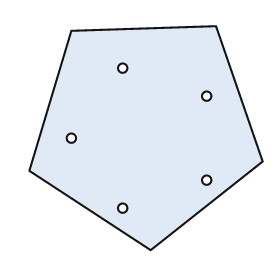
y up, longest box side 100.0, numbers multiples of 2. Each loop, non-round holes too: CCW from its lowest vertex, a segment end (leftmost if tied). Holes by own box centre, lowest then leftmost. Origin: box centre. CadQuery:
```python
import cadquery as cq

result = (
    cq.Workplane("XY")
    .moveTo(2.0, -48.0)
    .lineTo(50.0, -10.0)
    .lineTo(30.0, 48.0)
    .lineTo(-32.0, 46.0)
    .lineTo(-50.0, -14.0)
    .close()
    .moveTo(-10.0, -30.0)
    .circle(2.0)
    .moveTo(26.0, -18.0)
    .circle(2.0)
    .moveTo(-32.0, 0.0)
    .circle(2.0)
    .moveTo(26.0, 18.0)
    .circle(2.0)
    .moveTo(-10.0, 30.0)
    .circle(2.0)
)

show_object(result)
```